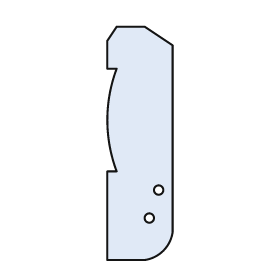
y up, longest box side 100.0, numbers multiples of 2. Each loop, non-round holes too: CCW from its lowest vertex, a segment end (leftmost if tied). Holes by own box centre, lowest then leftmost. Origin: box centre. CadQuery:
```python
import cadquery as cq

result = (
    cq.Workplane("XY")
    .moveTo(-14.0, -50.0)
    .lineTo(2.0, -50.0)
    .threePointArc((10.0, -46.0), (14.0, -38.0))
    .lineTo(14.0, 42.0)
    .lineTo(2.0, 50.0)
    .lineTo(-10.0, 50.0)
    .lineTo(-14.0, 44.0)
    .lineTo(-14.0, 32.0)
    .lineTo(-10.0, 32.0)
    .threePointArc((-14.0, 10.0), (-10.0, -12.0))
    .lineTo(-14.0, -12.0)
    .close()
    .moveTo(4.0, -32.0)
    .circle(2.0)
    .moveTo(8.0, -20.0)
    .circle(2.0)
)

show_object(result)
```